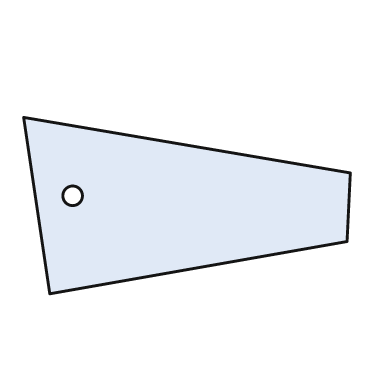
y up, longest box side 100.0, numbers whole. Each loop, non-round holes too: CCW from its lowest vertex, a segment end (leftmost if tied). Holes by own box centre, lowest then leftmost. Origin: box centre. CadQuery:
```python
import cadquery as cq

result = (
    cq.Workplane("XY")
    .moveTo(-42.0, -27.0)
    .lineTo(49.0, -11.0)
    .lineTo(50.0, 10.0)
    .lineTo(-50.0, 27.0)
    .close()
    .moveTo(-35.0, 3.0)
    .circle(3.0)
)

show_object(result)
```